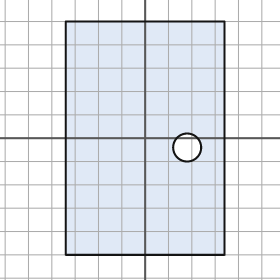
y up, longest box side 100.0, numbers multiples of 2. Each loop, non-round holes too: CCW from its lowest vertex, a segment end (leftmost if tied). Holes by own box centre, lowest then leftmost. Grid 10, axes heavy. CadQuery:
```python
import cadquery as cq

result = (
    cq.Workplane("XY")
    .moveTo(-34.0, -50.0)
    .lineTo(34.0, -50.0)
    .lineTo(34.0, 50.0)
    .lineTo(-34.0, 50.0)
    .close()
    .moveTo(18.0, -4.0)
    .circle(6.0)
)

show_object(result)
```